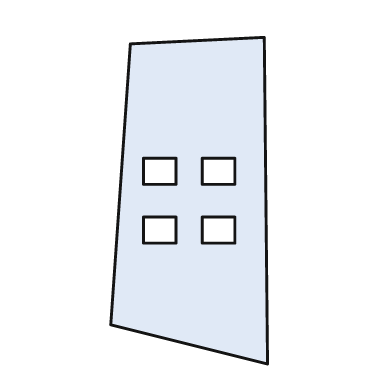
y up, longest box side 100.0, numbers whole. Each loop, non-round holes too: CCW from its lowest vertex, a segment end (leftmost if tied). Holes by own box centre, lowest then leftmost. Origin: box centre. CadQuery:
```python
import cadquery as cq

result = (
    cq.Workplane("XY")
    .moveTo(24.0, -50.0)
    .lineTo(23.0, 50.0)
    .lineTo(-18.0, 48.0)
    .lineTo(-24.0, -38.0)
    .close()
    .moveTo(-14.0, -13.0)
    .lineTo(-4.0, -13.0)
    .lineTo(-4.0, -5.0)
    .lineTo(-14.0, -5.0)
    .close()
    .moveTo(4.0, -13.0)
    .lineTo(14.0, -13.0)
    .lineTo(14.0, -5.0)
    .lineTo(4.0, -5.0)
    .close()
    .moveTo(-14.0, 5.0)
    .lineTo(-4.0, 5.0)
    .lineTo(-4.0, 13.0)
    .lineTo(-14.0, 13.0)
    .close()
    .moveTo(4.0, 5.0)
    .lineTo(14.0, 5.0)
    .lineTo(14.0, 13.0)
    .lineTo(4.0, 13.0)
    .close()
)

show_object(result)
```